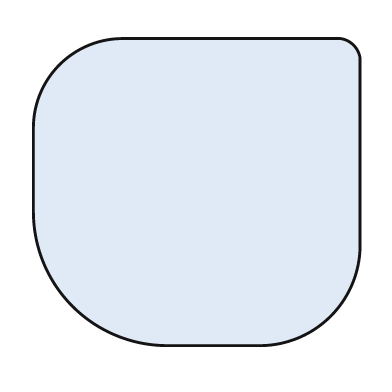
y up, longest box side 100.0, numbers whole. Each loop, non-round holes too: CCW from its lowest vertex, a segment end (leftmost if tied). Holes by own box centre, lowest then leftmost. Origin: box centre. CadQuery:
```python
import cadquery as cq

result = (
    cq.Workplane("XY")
    .moveTo(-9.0, -47.0)
    .lineTo(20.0, -47.0)
    .threePointArc((41.0, -38.0), (50.0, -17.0))
    .lineTo(50.0, 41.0)
    .threePointArc((48.0, 45.0), (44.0, 47.0))
    .lineTo(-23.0, 47.0)
    .threePointArc((-42.0, 39.0), (-50.0, 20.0))
    .lineTo(-50.0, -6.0)
    .threePointArc((-38.0, -35.0), (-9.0, -47.0))
    .close()
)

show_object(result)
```